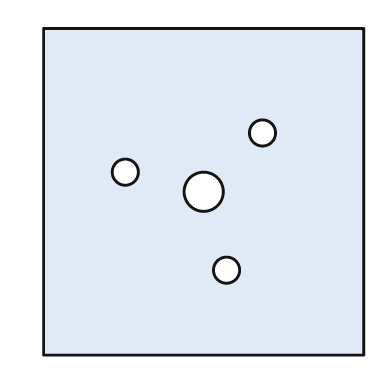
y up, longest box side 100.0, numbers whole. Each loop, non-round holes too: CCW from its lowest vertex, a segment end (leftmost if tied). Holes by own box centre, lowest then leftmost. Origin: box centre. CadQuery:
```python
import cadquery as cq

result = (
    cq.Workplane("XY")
    .moveTo(-49.0, -50.0)
    .lineTo(49.0, -50.0)
    .lineTo(49.0, 50.0)
    .lineTo(-49.0, 50.0)
    .close()
    .moveTo(7.0, -24.0)
    .circle(4.0)
    .moveTo(0.0, 0.0)
    .circle(6.0)
    .moveTo(-24.0, 6.0)
    .circle(4.0)
    .moveTo(18.0, 18.0)
    .circle(4.0)
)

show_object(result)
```